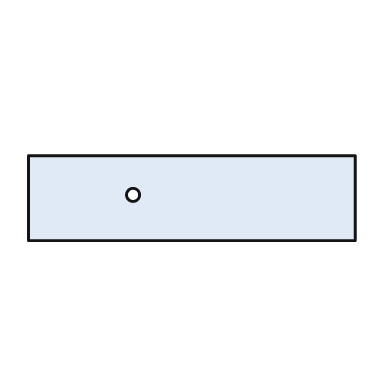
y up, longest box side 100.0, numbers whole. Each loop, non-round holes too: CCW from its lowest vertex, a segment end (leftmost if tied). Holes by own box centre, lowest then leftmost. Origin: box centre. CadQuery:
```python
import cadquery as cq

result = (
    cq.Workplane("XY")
    .moveTo(-50.0, -13.0)
    .lineTo(50.0, -13.0)
    .lineTo(50.0, 13.0)
    .lineTo(-50.0, 13.0)
    .close()
    .moveTo(-18.0, 1.0)
    .circle(2.0)
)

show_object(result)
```